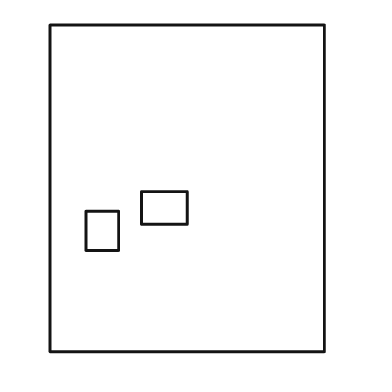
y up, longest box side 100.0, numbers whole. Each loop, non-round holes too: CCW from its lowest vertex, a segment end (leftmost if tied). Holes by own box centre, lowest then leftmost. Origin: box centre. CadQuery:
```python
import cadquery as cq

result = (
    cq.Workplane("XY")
    .moveTo(-42.0, -50.0)
    .lineTo(42.0, -50.0)
    .lineTo(42.0, 50.0)
    .lineTo(-42.0, 50.0)
    .close()
    .moveTo(-31.0, -19.0)
    .lineTo(-21.0, -19.0)
    .lineTo(-21.0, -7.0)
    .lineTo(-31.0, -7.0)
    .close()
    .moveTo(-14.0, -11.0)
    .lineTo(0.0, -11.0)
    .lineTo(0.0, -1.0)
    .lineTo(-14.0, -1.0)
    .close()
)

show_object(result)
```